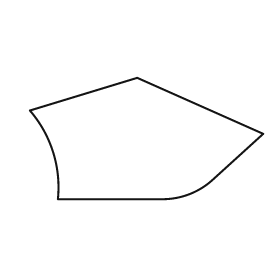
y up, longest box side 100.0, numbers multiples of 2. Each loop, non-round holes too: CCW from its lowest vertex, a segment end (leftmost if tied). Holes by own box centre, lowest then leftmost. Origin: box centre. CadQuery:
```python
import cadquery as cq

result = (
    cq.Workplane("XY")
    .moveTo(-38.0, -26.0)
    .lineTo(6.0, -26.0)
    .threePointArc((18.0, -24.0), (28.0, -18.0))
    .lineTo(50.0, 2.0)
    .lineTo(-4.0, 26.0)
    .lineTo(-50.0, 12.0)
    .threePointArc((-40.0, -6.0), (-38.0, -26.0))
    .close()
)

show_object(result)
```